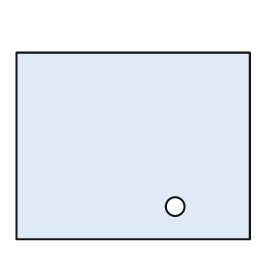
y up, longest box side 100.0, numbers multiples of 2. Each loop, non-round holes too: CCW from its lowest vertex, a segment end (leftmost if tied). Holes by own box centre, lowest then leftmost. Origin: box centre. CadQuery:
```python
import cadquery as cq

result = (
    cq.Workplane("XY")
    .moveTo(-50.0, -40.0)
    .lineTo(50.0, -40.0)
    .lineTo(50.0, 40.0)
    .lineTo(-50.0, 40.0)
    .close()
    .moveTo(18.0, -26.0)
    .circle(4.0)
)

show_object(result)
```